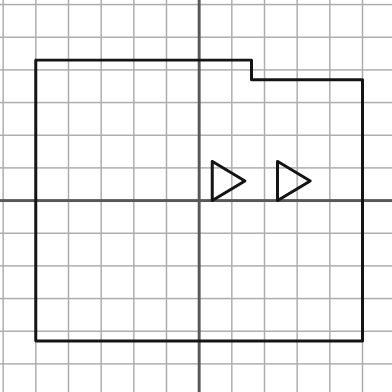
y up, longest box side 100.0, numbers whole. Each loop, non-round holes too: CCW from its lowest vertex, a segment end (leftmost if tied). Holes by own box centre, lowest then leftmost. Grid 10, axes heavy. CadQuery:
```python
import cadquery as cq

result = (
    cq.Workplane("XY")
    .moveTo(-50.0, -43.0)
    .lineTo(50.0, -43.0)
    .lineTo(50.0, 37.0)
    .lineTo(16.0, 37.0)
    .lineTo(16.0, 43.0)
    .lineTo(-50.0, 43.0)
    .close()
    .moveTo(4.0, 0.0)
    .lineTo(14.0, 6.0)
    .lineTo(4.0, 12.0)
    .close()
    .moveTo(24.0, 0.0)
    .lineTo(34.0, 6.0)
    .lineTo(24.0, 12.0)
    .close()
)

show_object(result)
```